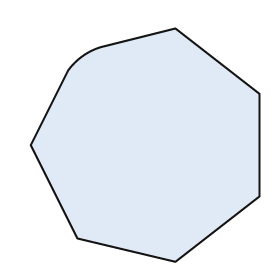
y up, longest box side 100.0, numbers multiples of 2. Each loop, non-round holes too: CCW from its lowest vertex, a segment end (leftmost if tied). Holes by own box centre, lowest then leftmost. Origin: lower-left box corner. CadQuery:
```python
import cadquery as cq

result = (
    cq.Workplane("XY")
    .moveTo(62.0, 0.0)
    .lineTo(98.0, 28.0)
    .lineTo(98.0, 72.0)
    .lineTo(62.0, 100.0)
    .lineTo(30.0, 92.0)
    .threePointArc((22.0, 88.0), (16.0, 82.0))
    .lineTo(0.0, 50.0)
    .lineTo(20.0, 10.0)
    .close()
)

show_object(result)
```